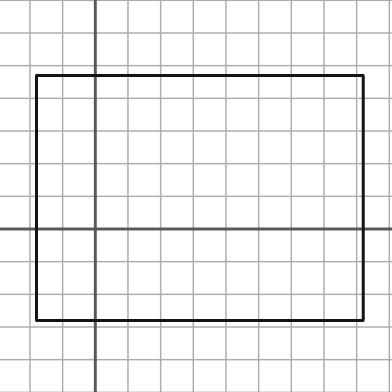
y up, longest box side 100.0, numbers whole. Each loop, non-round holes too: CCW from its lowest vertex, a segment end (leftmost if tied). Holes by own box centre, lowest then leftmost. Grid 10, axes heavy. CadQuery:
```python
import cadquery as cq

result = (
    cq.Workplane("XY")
    .moveTo(-18.0, -28.0)
    .lineTo(82.0, -28.0)
    .lineTo(82.0, 47.0)
    .lineTo(-18.0, 47.0)
    .close()
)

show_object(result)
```